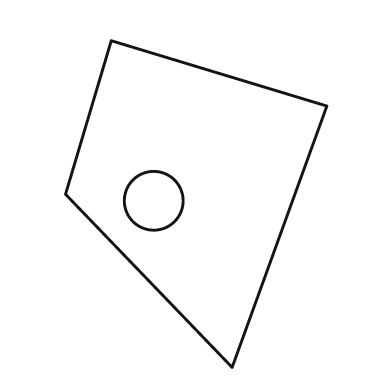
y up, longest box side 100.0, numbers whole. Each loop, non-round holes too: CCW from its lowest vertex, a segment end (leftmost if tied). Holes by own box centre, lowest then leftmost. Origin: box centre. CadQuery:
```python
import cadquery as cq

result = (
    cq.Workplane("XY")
    .moveTo(11.0, -50.0)
    .lineTo(40.0, 30.0)
    .lineTo(-26.0, 50.0)
    .lineTo(-40.0, 3.0)
    .close()
    .moveTo(-13.0, 1.0)
    .circle(9.0)
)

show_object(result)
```